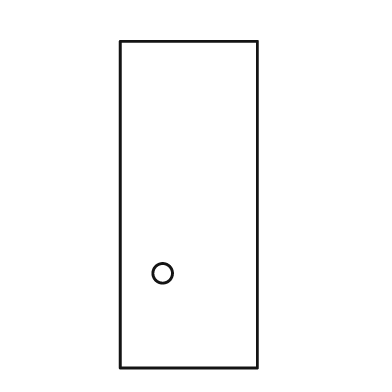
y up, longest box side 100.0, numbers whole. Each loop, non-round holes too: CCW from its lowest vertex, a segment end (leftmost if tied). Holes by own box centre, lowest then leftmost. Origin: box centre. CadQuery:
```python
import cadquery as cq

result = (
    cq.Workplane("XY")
    .moveTo(-21.0, -50.0)
    .lineTo(21.0, -50.0)
    .lineTo(21.0, 50.0)
    .lineTo(-21.0, 50.0)
    .close()
    .moveTo(-8.0, -21.0)
    .circle(3.0)
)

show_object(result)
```